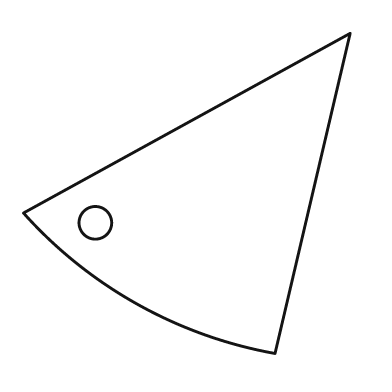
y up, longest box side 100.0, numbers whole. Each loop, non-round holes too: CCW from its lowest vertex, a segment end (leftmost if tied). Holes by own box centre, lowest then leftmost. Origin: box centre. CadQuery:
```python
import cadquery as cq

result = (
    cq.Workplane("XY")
    .moveTo(27.0, -49.0)
    .lineTo(50.0, 49.0)
    .lineTo(-50.0, -6.0)
    .threePointArc((-15.0, -34.0), (27.0, -49.0))
    .close()
    .moveTo(-28.0, -9.0)
    .circle(5.0)
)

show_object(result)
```